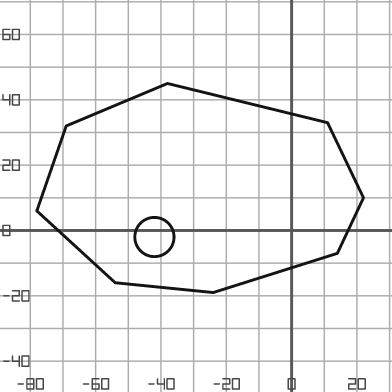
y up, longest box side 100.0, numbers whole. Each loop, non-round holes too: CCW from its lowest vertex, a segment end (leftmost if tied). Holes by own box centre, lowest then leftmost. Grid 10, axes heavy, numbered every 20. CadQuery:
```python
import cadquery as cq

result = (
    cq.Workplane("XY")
    .moveTo(-24.0, -19.0)
    .lineTo(14.0, -7.0)
    .lineTo(22.0, 10.0)
    .lineTo(11.0, 33.0)
    .lineTo(-38.0, 45.0)
    .lineTo(-69.0, 32.0)
    .lineTo(-78.0, 6.0)
    .lineTo(-54.0, -16.0)
    .close()
    .moveTo(-42.0, -2.0)
    .circle(6.0)
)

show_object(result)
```